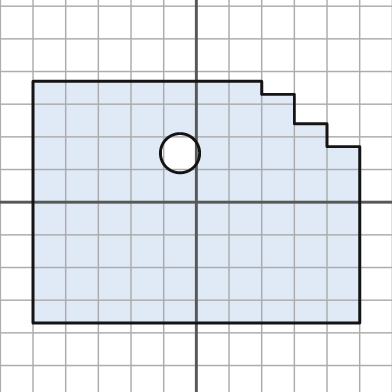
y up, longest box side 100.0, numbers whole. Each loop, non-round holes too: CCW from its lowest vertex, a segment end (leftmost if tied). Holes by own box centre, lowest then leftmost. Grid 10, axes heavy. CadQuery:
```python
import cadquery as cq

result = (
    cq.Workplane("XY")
    .moveTo(-50.0, -37.0)
    .lineTo(50.0, -37.0)
    .lineTo(50.0, 17.0)
    .lineTo(40.0, 17.0)
    .lineTo(40.0, 24.0)
    .lineTo(30.0, 24.0)
    .lineTo(30.0, 33.0)
    .lineTo(20.0, 33.0)
    .lineTo(20.0, 37.0)
    .lineTo(-50.0, 37.0)
    .close()
    .moveTo(-5.0, 15.0)
    .circle(6.0)
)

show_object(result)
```